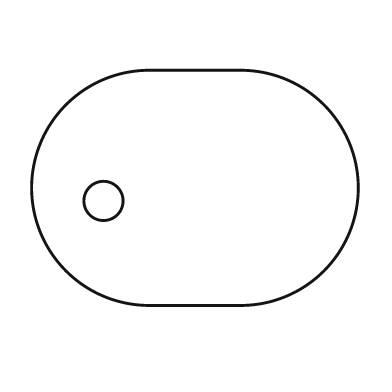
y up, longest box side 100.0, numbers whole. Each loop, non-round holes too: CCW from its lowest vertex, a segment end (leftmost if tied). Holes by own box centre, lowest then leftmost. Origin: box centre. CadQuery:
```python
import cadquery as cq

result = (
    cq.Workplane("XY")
    .moveTo(-14.0, -36.0)
    .lineTo(14.0, -36.0)
    .threePointArc((50.0, 0.0), (14.0, 36.0))
    .lineTo(-14.0, 36.0)
    .threePointArc((-50.0, 0.0), (-14.0, -36.0))
    .close()
    .moveTo(-28.0, -4.0)
    .circle(6.0)
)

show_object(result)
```